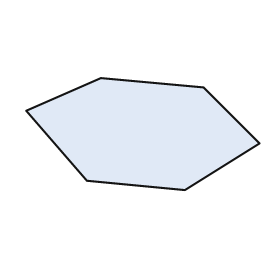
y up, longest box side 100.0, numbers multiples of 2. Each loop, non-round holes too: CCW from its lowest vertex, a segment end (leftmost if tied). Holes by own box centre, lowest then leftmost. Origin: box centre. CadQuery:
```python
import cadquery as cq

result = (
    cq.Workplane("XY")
    .moveTo(18.0, -24.0)
    .lineTo(50.0, -4.0)
    .lineTo(26.0, 20.0)
    .lineTo(-18.0, 24.0)
    .lineTo(-50.0, 10.0)
    .lineTo(-24.0, -20.0)
    .close()
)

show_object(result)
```